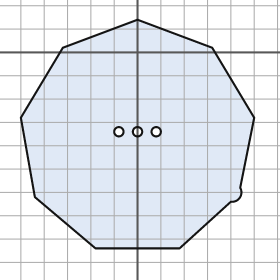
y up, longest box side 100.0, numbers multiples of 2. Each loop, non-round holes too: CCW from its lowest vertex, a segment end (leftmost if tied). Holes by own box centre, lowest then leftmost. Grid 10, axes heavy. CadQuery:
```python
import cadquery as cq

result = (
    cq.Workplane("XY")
    .moveTo(-18.0, -84.0)
    .lineTo(18.0, -84.0)
    .lineTo(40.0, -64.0)
    .threePointArc((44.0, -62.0), (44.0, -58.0))
    .lineTo(50.0, -28.0)
    .lineTo(32.0, 2.0)
    .lineTo(0.0, 14.0)
    .lineTo(-32.0, 2.0)
    .lineTo(-50.0, -28.0)
    .lineTo(-44.0, -62.0)
    .close()
    .moveTo(-8.0, -34.0)
    .circle(2.0)
    .moveTo(0.0, -34.0)
    .circle(2.0)
    .moveTo(8.0, -34.0)
    .circle(2.0)
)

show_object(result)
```